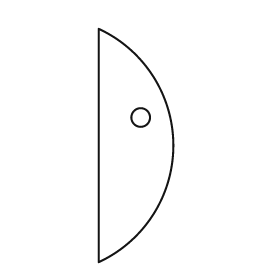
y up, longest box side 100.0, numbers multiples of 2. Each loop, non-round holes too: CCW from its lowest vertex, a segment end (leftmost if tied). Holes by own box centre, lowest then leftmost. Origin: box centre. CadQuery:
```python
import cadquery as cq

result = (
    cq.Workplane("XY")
    .moveTo(-16.0, -50.0)
    .threePointArc((16.0, 0.0), (-16.0, 50.0))
    .close()
    .moveTo(2.0, 12.0)
    .circle(4.0)
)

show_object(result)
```